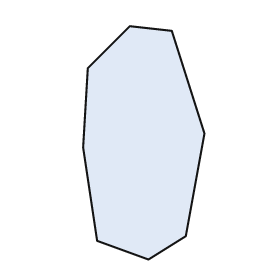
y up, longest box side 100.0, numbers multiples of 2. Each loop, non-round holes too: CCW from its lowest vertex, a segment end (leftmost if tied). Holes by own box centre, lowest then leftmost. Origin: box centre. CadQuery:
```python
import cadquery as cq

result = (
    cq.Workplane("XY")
    .moveTo(2.0, -50.0)
    .lineTo(18.0, -40.0)
    .lineTo(26.0, 4.0)
    .lineTo(12.0, 48.0)
    .lineTo(-6.0, 50.0)
    .lineTo(-24.0, 32.0)
    .lineTo(-26.0, -2.0)
    .lineTo(-20.0, -42.0)
    .close()
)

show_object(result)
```